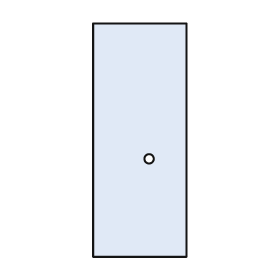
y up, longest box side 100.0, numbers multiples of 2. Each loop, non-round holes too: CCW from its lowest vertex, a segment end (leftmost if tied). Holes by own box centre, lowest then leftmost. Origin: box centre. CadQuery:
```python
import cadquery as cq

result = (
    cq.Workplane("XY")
    .moveTo(-20.0, -50.0)
    .lineTo(20.0, -50.0)
    .lineTo(20.0, 50.0)
    .lineTo(-20.0, 50.0)
    .close()
    .moveTo(4.0, -8.0)
    .circle(2.0)
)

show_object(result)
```